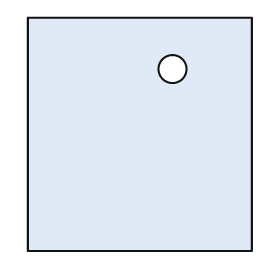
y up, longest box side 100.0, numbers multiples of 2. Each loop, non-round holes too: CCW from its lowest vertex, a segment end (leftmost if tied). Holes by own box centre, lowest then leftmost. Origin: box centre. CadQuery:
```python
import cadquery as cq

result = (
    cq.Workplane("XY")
    .moveTo(-48.0, -50.0)
    .lineTo(48.0, -50.0)
    .lineTo(48.0, 50.0)
    .lineTo(-48.0, 50.0)
    .close()
    .moveTo(14.0, 28.0)
    .circle(6.0)
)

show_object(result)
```